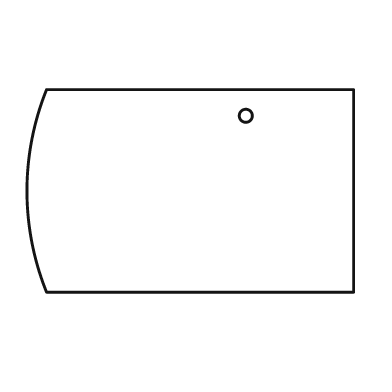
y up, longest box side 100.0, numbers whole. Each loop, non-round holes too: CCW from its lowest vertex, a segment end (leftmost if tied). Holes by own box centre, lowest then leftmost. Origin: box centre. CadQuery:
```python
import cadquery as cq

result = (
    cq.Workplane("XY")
    .moveTo(-44.0, -31.0)
    .lineTo(50.0, -31.0)
    .lineTo(50.0, 31.0)
    .lineTo(-44.0, 31.0)
    .threePointArc((-50.0, 0.0), (-44.0, -31.0))
    .close()
    .moveTo(17.0, 23.0)
    .circle(2.0)
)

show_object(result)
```